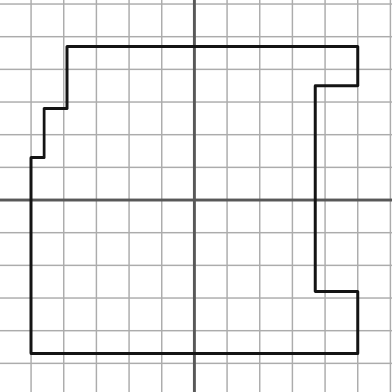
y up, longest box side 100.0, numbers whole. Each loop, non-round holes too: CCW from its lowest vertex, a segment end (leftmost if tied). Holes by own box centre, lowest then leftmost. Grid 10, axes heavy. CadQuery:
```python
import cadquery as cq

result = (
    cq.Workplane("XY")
    .moveTo(-50.0, -47.0)
    .lineTo(50.0, -47.0)
    .lineTo(50.0, -28.0)
    .lineTo(37.0, -28.0)
    .lineTo(37.0, 35.0)
    .lineTo(50.0, 35.0)
    .lineTo(50.0, 47.0)
    .lineTo(-39.0, 47.0)
    .lineTo(-39.0, 28.0)
    .lineTo(-46.0, 28.0)
    .lineTo(-46.0, 13.0)
    .lineTo(-50.0, 13.0)
    .close()
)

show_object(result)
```